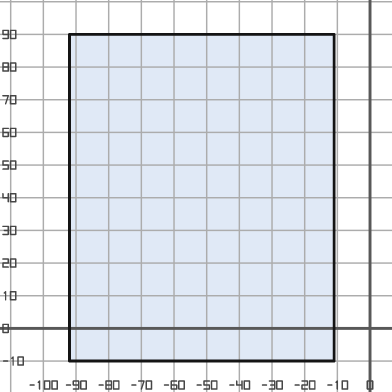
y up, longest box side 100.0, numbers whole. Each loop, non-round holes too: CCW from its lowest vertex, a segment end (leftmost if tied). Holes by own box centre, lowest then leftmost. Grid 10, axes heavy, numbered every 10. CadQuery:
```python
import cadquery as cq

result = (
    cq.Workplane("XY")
    .moveTo(-92.0, -10.0)
    .lineTo(-11.0, -10.0)
    .lineTo(-11.0, 90.0)
    .lineTo(-92.0, 90.0)
    .close()
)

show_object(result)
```